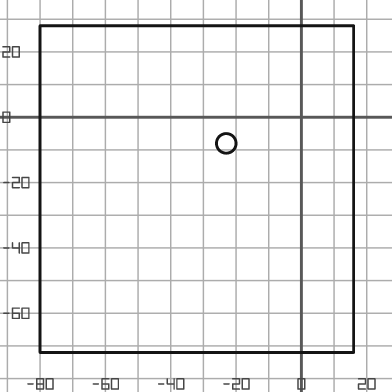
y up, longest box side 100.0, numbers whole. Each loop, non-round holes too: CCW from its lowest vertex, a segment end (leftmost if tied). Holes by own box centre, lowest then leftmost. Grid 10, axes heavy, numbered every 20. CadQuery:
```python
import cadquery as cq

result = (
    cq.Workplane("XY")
    .moveTo(-80.0, -72.0)
    .lineTo(16.0, -72.0)
    .lineTo(16.0, 28.0)
    .lineTo(-80.0, 28.0)
    .close()
    .moveTo(-23.0, -8.0)
    .circle(3.0)
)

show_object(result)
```